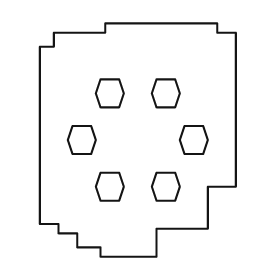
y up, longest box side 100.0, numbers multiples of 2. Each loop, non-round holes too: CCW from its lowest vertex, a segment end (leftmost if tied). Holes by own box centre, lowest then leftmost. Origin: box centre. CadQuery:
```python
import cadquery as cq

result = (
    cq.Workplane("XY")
    .moveTo(-16.0, -50.0)
    .lineTo(8.0, -50.0)
    .lineTo(8.0, -38.0)
    .lineTo(30.0, -38.0)
    .lineTo(30.0, -20.0)
    .lineTo(42.0, -20.0)
    .lineTo(42.0, 46.0)
    .lineTo(34.0, 46.0)
    .lineTo(34.0, 50.0)
    .lineTo(-14.0, 50.0)
    .lineTo(-14.0, 46.0)
    .lineTo(-36.0, 46.0)
    .lineTo(-36.0, 40.0)
    .lineTo(-42.0, 40.0)
    .lineTo(-42.0, -36.0)
    .lineTo(-34.0, -36.0)
    .lineTo(-34.0, -40.0)
    .lineTo(-26.0, -40.0)
    .lineTo(-26.0, -46.0)
    .lineTo(-16.0, -46.0)
    .close()
    .moveTo(-16.0, -26.0)
    .lineTo(-8.0, -26.0)
    .lineTo(-6.0, -20.0)
    .lineTo(-8.0, -14.0)
    .lineTo(-16.0, -14.0)
    .lineTo(-18.0, -20.0)
    .close()
    .moveTo(8.0, -26.0)
    .lineTo(16.0, -26.0)
    .lineTo(18.0, -20.0)
    .lineTo(16.0, -14.0)
    .lineTo(8.0, -14.0)
    .lineTo(6.0, -20.0)
    .close()
    .moveTo(-28.0, -6.0)
    .lineTo(-20.0, -6.0)
    .lineTo(-18.0, 0.0)
    .lineTo(-20.0, 6.0)
    .lineTo(-28.0, 6.0)
    .lineTo(-30.0, 0.0)
    .close()
    .moveTo(20.0, -6.0)
    .lineTo(28.0, -6.0)
    .lineTo(30.0, 0.0)
    .lineTo(28.0, 6.0)
    .lineTo(20.0, 6.0)
    .lineTo(18.0, 0.0)
    .close()
    .moveTo(-16.0, 14.0)
    .lineTo(-8.0, 14.0)
    .lineTo(-6.0, 20.0)
    .lineTo(-8.0, 26.0)
    .lineTo(-16.0, 26.0)
    .lineTo(-18.0, 20.0)
    .close()
    .moveTo(8.0, 14.0)
    .lineTo(16.0, 14.0)
    .lineTo(18.0, 20.0)
    .lineTo(16.0, 26.0)
    .lineTo(8.0, 26.0)
    .lineTo(6.0, 20.0)
    .close()
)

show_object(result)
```